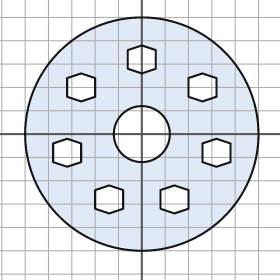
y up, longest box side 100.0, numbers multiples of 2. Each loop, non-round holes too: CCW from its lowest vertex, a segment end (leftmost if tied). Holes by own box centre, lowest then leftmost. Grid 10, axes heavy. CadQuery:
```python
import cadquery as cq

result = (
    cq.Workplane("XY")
    .moveTo(0.0, 0.0)
    .circle(50.0)
    .moveTo(-14.0, -34.0)
    .lineTo(-8.0, -32.0)
    .lineTo(-8.0, -24.0)
    .lineTo(-14.0, -22.0)
    .lineTo(-20.0, -24.0)
    .lineTo(-20.0, -32.0)
    .close()
    .moveTo(14.0, -34.0)
    .lineTo(20.0, -32.0)
    .lineTo(20.0, -24.0)
    .lineTo(14.0, -22.0)
    .lineTo(8.0, -24.0)
    .lineTo(8.0, -32.0)
    .close()
    .moveTo(-32.0, -14.0)
    .lineTo(-26.0, -12.0)
    .lineTo(-26.0, -4.0)
    .lineTo(-32.0, -2.0)
    .lineTo(-38.0, -4.0)
    .lineTo(-38.0, -12.0)
    .close()
    .moveTo(32.0, -14.0)
    .lineTo(38.0, -12.0)
    .lineTo(38.0, -4.0)
    .lineTo(32.0, -2.0)
    .lineTo(26.0, -4.0)
    .lineTo(26.0, -12.0)
    .close()
    .moveTo(0.0, 0.0)
    .circle(12.0)
    .moveTo(-26.0, 14.0)
    .lineTo(-20.0, 16.0)
    .lineTo(-20.0, 24.0)
    .lineTo(-26.0, 26.0)
    .lineTo(-32.0, 24.0)
    .lineTo(-32.0, 16.0)
    .close()
    .moveTo(26.0, 14.0)
    .lineTo(32.0, 16.0)
    .lineTo(32.0, 24.0)
    .lineTo(26.0, 26.0)
    .lineTo(20.0, 24.0)
    .lineTo(20.0, 16.0)
    .close()
    .moveTo(0.0, 26.0)
    .lineTo(6.0, 28.0)
    .lineTo(6.0, 36.0)
    .lineTo(0.0, 38.0)
    .lineTo(-6.0, 36.0)
    .lineTo(-6.0, 28.0)
    .close()
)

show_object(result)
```